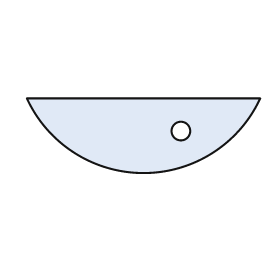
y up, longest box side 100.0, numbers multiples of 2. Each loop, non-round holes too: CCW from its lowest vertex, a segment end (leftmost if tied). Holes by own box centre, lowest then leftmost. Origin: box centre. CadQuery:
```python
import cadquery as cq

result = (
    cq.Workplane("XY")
    .moveTo(-50.0, 16.0)
    .threePointArc((0.0, -16.0), (50.0, 16.0))
    .close()
    .moveTo(16.0, 2.0)
    .circle(4.0)
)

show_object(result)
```